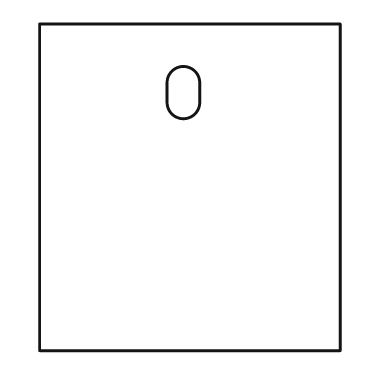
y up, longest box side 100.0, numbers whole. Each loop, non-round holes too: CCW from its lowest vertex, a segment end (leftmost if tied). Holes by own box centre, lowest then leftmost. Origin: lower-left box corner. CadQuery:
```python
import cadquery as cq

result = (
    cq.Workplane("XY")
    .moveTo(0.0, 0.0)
    .lineTo(92.0, 0.0)
    .lineTo(92.0, 100.0)
    .lineTo(0.0, 100.0)
    .close()
    .moveTo(39.0, 76.0)
    .threePointArc((44.0, 71.0), (49.0, 76.0))
    .lineTo(49.0, 82.0)
    .threePointArc((44.0, 87.0), (39.0, 82.0))
    .close()
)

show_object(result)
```